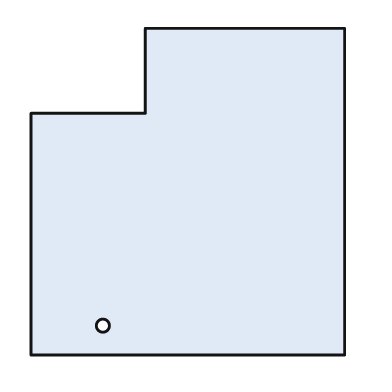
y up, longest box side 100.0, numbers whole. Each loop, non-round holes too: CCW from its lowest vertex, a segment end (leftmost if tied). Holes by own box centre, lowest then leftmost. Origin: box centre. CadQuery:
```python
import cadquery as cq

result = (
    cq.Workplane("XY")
    .moveTo(-48.0, -50.0)
    .lineTo(48.0, -50.0)
    .lineTo(48.0, 50.0)
    .lineTo(-13.0, 50.0)
    .lineTo(-13.0, 24.0)
    .lineTo(-48.0, 24.0)
    .close()
    .moveTo(-26.0, -41.0)
    .circle(2.0)
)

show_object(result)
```